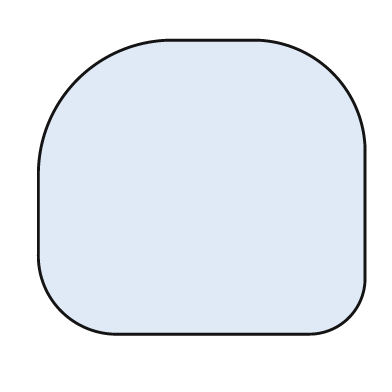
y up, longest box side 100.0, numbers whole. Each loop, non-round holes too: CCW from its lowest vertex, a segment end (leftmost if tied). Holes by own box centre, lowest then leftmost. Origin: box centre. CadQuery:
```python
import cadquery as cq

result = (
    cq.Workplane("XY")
    .moveTo(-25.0, -45.0)
    .lineTo(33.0, -45.0)
    .threePointArc((45.0, -40.0), (50.0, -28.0))
    .lineTo(50.0, 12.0)
    .threePointArc((40.0, 35.0), (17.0, 45.0))
    .lineTo(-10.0, 45.0)
    .threePointArc((-38.0, 33.0), (-50.0, 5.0))
    .lineTo(-50.0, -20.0)
    .threePointArc((-43.0, -38.0), (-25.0, -45.0))
    .close()
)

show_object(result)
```